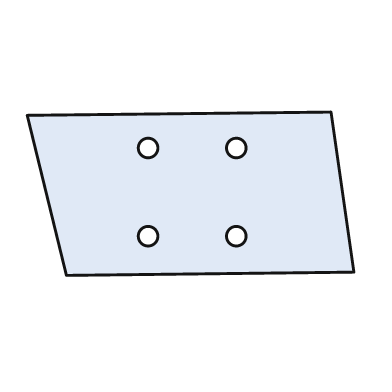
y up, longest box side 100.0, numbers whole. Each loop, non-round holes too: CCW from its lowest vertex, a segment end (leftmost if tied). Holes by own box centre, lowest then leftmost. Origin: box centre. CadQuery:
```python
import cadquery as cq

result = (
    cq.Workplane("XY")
    .moveTo(-38.0, -25.0)
    .lineTo(50.0, -24.0)
    .lineTo(43.0, 25.0)
    .lineTo(-50.0, 24.0)
    .close()
    .moveTo(-13.0, -13.0)
    .circle(3.0)
    .moveTo(14.0, -13.0)
    .circle(3.0)
    .moveTo(-13.0, 14.0)
    .circle(3.0)
    .moveTo(14.0, 14.0)
    .circle(3.0)
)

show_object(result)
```